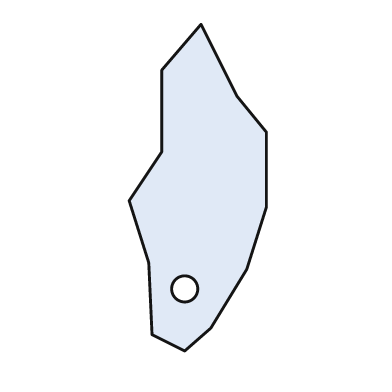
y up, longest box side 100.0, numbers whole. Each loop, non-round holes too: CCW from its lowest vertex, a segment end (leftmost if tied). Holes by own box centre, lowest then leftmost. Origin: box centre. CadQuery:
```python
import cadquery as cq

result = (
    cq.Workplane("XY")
    .moveTo(-4.0, -50.0)
    .lineTo(4.0, -43.0)
    .lineTo(15.0, -25.0)
    .lineTo(21.0, -6.0)
    .lineTo(21.0, 17.0)
    .lineTo(12.0, 28.0)
    .lineTo(1.0, 50.0)
    .lineTo(-11.0, 36.0)
    .lineTo(-11.0, 11.0)
    .lineTo(-21.0, -4.0)
    .lineTo(-15.0, -23.0)
    .lineTo(-14.0, -45.0)
    .close()
    .moveTo(-4.0, -31.0)
    .circle(4.0)
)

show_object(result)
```